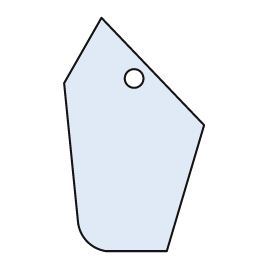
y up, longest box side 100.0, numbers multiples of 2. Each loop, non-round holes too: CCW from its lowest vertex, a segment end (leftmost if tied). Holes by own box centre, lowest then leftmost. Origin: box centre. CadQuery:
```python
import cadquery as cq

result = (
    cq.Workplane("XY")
    .moveTo(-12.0, -50.0)
    .lineTo(14.0, -50.0)
    .lineTo(30.0, 4.0)
    .lineTo(-14.0, 50.0)
    .lineTo(-30.0, 22.0)
    .lineTo(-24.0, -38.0)
    .threePointArc((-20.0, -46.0), (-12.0, -50.0))
    .close()
    .moveTo(0.0, 24.0)
    .circle(4.0)
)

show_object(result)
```